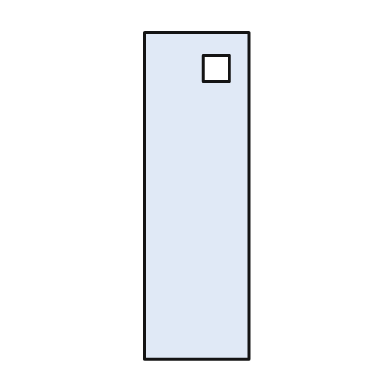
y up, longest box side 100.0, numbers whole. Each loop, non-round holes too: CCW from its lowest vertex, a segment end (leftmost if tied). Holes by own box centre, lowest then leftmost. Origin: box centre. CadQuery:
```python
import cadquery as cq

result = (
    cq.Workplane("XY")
    .moveTo(-16.0, -50.0)
    .lineTo(16.0, -50.0)
    .lineTo(16.0, 50.0)
    .lineTo(-16.0, 50.0)
    .close()
    .moveTo(2.0, 35.0)
    .lineTo(10.0, 35.0)
    .lineTo(10.0, 43.0)
    .lineTo(2.0, 43.0)
    .close()
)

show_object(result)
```